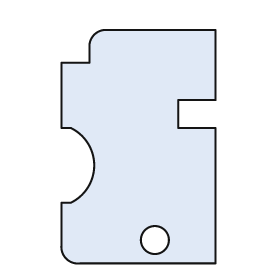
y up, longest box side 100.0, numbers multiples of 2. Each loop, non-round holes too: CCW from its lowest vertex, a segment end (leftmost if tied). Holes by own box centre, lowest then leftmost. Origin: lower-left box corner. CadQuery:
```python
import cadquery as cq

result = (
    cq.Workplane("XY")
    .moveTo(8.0, 0.0)
    .lineTo(66.0, 0.0)
    .lineTo(66.0, 58.0)
    .lineTo(50.0, 58.0)
    .lineTo(50.0, 70.0)
    .lineTo(66.0, 70.0)
    .lineTo(66.0, 100.0)
    .lineTo(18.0, 100.0)
    .threePointArc((14.0, 98.0), (12.0, 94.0))
    .lineTo(12.0, 86.0)
    .lineTo(0.0, 86.0)
    .lineTo(0.0, 58.0)
    .lineTo(4.0, 58.0)
    .threePointArc((14.0, 42.0), (4.0, 26.0))
    .lineTo(0.0, 26.0)
    .lineTo(0.0, 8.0)
    .threePointArc((2.0, 2.0), (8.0, 0.0))
    .close()
    .moveTo(40.0, 10.0)
    .circle(6.0)
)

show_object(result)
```